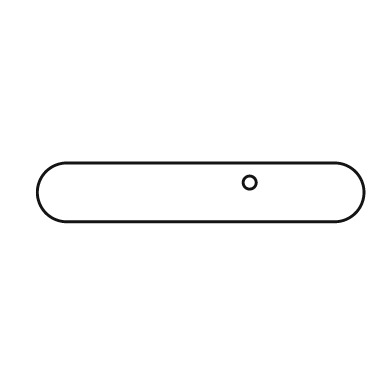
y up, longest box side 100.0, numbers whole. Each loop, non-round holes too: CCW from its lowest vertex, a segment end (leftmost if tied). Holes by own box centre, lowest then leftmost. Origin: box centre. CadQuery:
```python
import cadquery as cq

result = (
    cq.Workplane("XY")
    .moveTo(-41.0, -9.0)
    .lineTo(41.0, -9.0)
    .threePointArc((50.0, 0.0), (41.0, 9.0))
    .lineTo(-41.0, 9.0)
    .threePointArc((-50.0, 0.0), (-41.0, -9.0))
    .close()
    .moveTo(15.0, 3.0)
    .circle(2.0)
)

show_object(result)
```